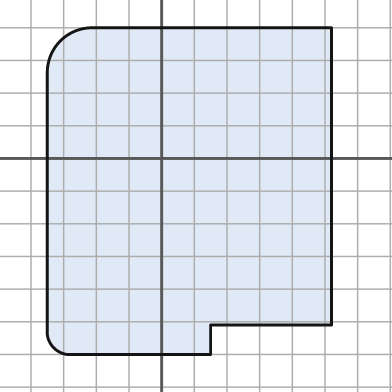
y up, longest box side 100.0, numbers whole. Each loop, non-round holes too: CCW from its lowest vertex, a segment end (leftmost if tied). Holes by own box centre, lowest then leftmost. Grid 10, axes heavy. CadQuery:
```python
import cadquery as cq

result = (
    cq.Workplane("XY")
    .moveTo(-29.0, -60.0)
    .lineTo(15.0, -60.0)
    .lineTo(15.0, -51.0)
    .lineTo(52.0, -51.0)
    .lineTo(52.0, 40.0)
    .lineTo(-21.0, 40.0)
    .threePointArc((-31.0, 36.0), (-35.0, 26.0))
    .lineTo(-35.0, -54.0)
    .threePointArc((-33.0, -58.0), (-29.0, -60.0))
    .close()
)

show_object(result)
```